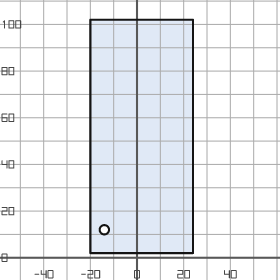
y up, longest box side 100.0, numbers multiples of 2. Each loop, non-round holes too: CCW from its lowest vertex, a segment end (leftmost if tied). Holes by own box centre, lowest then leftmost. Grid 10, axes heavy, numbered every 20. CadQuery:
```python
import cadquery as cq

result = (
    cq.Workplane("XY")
    .moveTo(-20.0, 2.0)
    .lineTo(24.0, 2.0)
    .lineTo(24.0, 102.0)
    .lineTo(-20.0, 102.0)
    .close()
    .moveTo(-14.0, 12.0)
    .circle(2.0)
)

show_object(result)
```